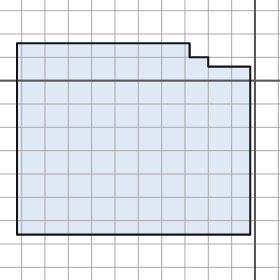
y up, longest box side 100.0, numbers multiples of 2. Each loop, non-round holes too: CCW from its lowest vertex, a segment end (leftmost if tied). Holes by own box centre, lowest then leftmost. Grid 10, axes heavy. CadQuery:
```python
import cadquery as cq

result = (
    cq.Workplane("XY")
    .moveTo(-102.0, -66.0)
    .lineTo(-2.0, -66.0)
    .lineTo(-2.0, 6.0)
    .lineTo(-20.0, 6.0)
    .lineTo(-20.0, 10.0)
    .lineTo(-28.0, 10.0)
    .lineTo(-28.0, 16.0)
    .lineTo(-102.0, 16.0)
    .close()
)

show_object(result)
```